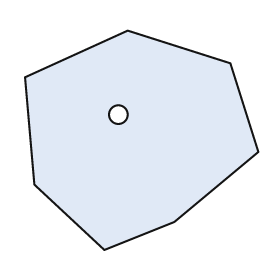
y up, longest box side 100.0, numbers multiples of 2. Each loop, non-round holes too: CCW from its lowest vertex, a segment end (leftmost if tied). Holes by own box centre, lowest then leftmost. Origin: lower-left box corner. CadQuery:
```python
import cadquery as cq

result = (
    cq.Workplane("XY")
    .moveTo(34.0, 0.0)
    .lineTo(64.0, 12.0)
    .lineTo(100.0, 42.0)
    .lineTo(88.0, 80.0)
    .lineTo(44.0, 94.0)
    .lineTo(0.0, 74.0)
    .lineTo(4.0, 28.0)
    .close()
    .moveTo(40.0, 58.0)
    .circle(4.0)
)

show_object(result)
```